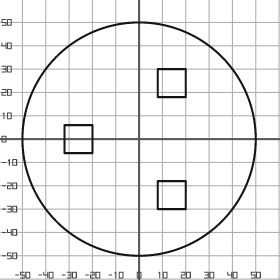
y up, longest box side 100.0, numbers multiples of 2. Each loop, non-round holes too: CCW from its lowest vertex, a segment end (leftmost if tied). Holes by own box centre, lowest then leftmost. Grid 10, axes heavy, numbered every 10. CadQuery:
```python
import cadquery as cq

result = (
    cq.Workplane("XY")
    .moveTo(0.0, 0.0)
    .circle(50.0)
    .moveTo(8.0, -30.0)
    .lineTo(20.0, -30.0)
    .lineTo(20.0, -18.0)
    .lineTo(8.0, -18.0)
    .close()
    .moveTo(-32.0, -6.0)
    .lineTo(-20.0, -6.0)
    .lineTo(-20.0, 6.0)
    .lineTo(-32.0, 6.0)
    .close()
    .moveTo(8.0, 18.0)
    .lineTo(20.0, 18.0)
    .lineTo(20.0, 30.0)
    .lineTo(8.0, 30.0)
    .close()
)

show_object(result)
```